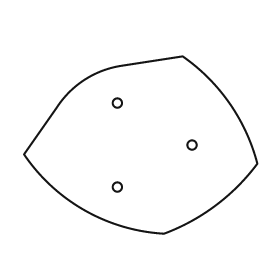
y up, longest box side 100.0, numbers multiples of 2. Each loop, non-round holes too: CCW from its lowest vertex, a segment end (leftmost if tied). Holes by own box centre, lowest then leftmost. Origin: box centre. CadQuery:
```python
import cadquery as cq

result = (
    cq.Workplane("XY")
    .moveTo(10.0, -38.0)
    .threePointArc((32.0, -26.0), (50.0, -8.0))
    .threePointArc((38.0, 18.0), (18.0, 38.0))
    .lineTo(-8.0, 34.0)
    .threePointArc((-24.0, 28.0), (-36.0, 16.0))
    .lineTo(-50.0, -4.0)
    .threePointArc((-24.0, -28.0), (10.0, -38.0))
    .close()
    .moveTo(-10.0, -18.0)
    .circle(2.0)
    .moveTo(22.0, 0.0)
    .circle(2.0)
    .moveTo(-10.0, 18.0)
    .circle(2.0)
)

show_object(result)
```